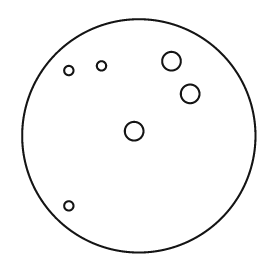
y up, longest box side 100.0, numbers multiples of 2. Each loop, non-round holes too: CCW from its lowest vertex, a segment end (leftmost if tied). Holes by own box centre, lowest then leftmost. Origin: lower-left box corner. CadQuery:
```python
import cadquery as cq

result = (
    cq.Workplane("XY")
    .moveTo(50.0, 50.0)
    .circle(50.0)
    .moveTo(20.0, 20.0)
    .circle(2.0)
    .moveTo(48.0, 52.0)
    .circle(4.0)
    .moveTo(72.0, 68.0)
    .circle(4.0)
    .moveTo(20.0, 78.0)
    .circle(2.0)
    .moveTo(34.0, 80.0)
    .circle(2.0)
    .moveTo(64.0, 82.0)
    .circle(4.0)
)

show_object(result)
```